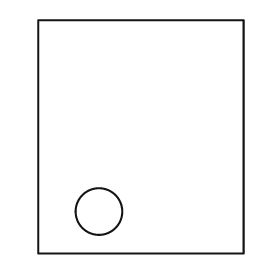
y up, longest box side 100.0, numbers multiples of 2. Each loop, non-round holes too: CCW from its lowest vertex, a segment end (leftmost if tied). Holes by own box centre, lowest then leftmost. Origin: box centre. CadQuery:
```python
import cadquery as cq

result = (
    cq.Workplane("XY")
    .moveTo(-44.0, -50.0)
    .lineTo(44.0, -50.0)
    .lineTo(44.0, 50.0)
    .lineTo(-44.0, 50.0)
    .close()
    .moveTo(-18.0, -32.0)
    .circle(10.0)
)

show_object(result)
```